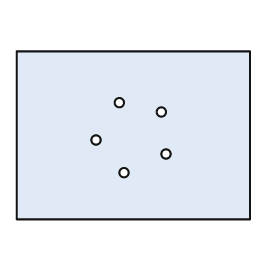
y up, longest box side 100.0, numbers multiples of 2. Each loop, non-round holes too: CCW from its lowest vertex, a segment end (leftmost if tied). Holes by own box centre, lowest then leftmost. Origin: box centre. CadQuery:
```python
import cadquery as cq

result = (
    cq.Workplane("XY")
    .moveTo(-50.0, -36.0)
    .lineTo(50.0, -36.0)
    .lineTo(50.0, 36.0)
    .lineTo(-50.0, 36.0)
    .close()
    .moveTo(-4.0, -16.0)
    .circle(2.0)
    .moveTo(14.0, -8.0)
    .circle(2.0)
    .moveTo(-16.0, -2.0)
    .circle(2.0)
    .moveTo(12.0, 10.0)
    .circle(2.0)
    .moveTo(-6.0, 14.0)
    .circle(2.0)
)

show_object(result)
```